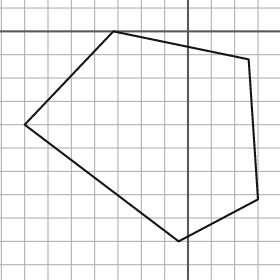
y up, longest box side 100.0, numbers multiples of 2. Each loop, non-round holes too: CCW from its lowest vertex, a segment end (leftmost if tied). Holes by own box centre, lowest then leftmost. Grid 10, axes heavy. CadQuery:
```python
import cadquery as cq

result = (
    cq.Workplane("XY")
    .moveTo(-4.0, -90.0)
    .lineTo(30.0, -72.0)
    .lineTo(26.0, -12.0)
    .lineTo(-32.0, 0.0)
    .lineTo(-70.0, -40.0)
    .close()
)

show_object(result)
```